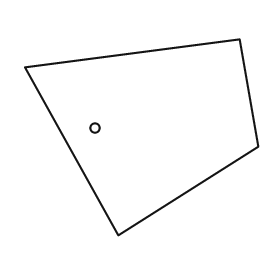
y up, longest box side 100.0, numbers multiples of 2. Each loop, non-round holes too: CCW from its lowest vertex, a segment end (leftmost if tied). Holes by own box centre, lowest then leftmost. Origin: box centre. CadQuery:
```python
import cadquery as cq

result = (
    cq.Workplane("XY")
    .moveTo(-10.0, -42.0)
    .lineTo(50.0, -4.0)
    .lineTo(42.0, 42.0)
    .lineTo(-50.0, 30.0)
    .close()
    .moveTo(-20.0, 4.0)
    .circle(2.0)
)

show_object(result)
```